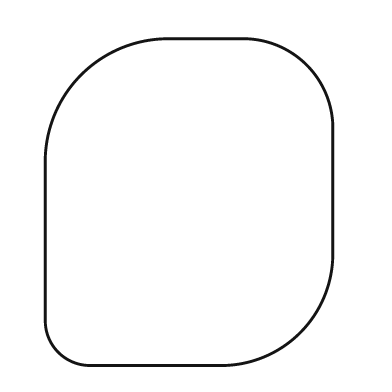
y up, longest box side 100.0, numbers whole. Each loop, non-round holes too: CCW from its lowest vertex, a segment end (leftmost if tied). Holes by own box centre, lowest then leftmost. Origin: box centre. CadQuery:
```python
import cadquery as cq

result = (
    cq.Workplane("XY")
    .moveTo(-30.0, -50.0)
    .lineTo(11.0, -50.0)
    .threePointArc((34.0, -40.0), (44.0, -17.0))
    .lineTo(44.0, 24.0)
    .threePointArc((36.0, 42.0), (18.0, 50.0))
    .lineTo(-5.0, 50.0)
    .threePointArc((-33.0, 39.0), (-44.0, 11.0))
    .lineTo(-44.0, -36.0)
    .threePointArc((-40.0, -46.0), (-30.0, -50.0))
    .close()
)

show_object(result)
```